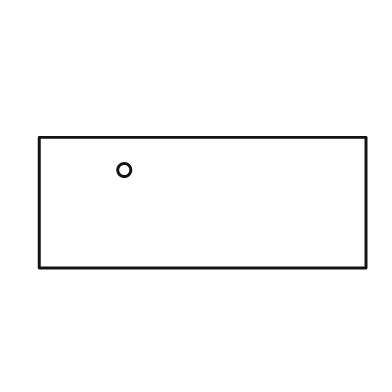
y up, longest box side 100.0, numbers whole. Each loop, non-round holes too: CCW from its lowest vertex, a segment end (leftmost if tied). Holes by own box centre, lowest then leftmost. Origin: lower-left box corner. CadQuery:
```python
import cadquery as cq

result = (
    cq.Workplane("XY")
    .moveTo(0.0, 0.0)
    .lineTo(100.0, 0.0)
    .lineTo(100.0, 40.0)
    .lineTo(0.0, 40.0)
    .close()
    .moveTo(26.0, 30.0)
    .circle(2.0)
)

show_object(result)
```